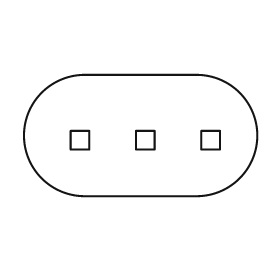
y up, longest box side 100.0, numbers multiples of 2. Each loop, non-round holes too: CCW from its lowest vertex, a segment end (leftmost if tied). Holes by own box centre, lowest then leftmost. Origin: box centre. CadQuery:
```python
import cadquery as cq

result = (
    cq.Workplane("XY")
    .moveTo(-24.0, -26.0)
    .lineTo(24.0, -26.0)
    .threePointArc((50.0, 0.0), (24.0, 26.0))
    .lineTo(-24.0, 26.0)
    .threePointArc((-50.0, 0.0), (-24.0, -26.0))
    .close()
    .moveTo(-30.0, -6.0)
    .lineTo(-22.0, -6.0)
    .lineTo(-22.0, 2.0)
    .lineTo(-30.0, 2.0)
    .close()
    .moveTo(-2.0, -6.0)
    .lineTo(6.0, -6.0)
    .lineTo(6.0, 2.0)
    .lineTo(-2.0, 2.0)
    .close()
    .moveTo(26.0, -6.0)
    .lineTo(34.0, -6.0)
    .lineTo(34.0, 2.0)
    .lineTo(26.0, 2.0)
    .close()
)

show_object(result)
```